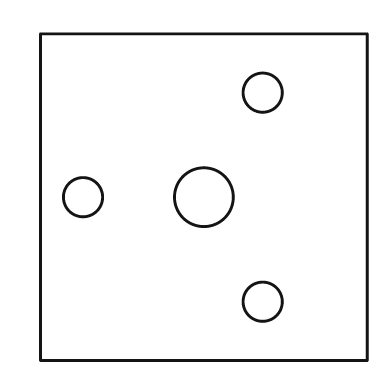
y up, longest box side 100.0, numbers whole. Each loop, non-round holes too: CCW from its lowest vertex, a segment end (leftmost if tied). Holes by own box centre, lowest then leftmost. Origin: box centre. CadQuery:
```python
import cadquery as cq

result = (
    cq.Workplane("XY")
    .moveTo(-50.0, -50.0)
    .lineTo(50.0, -50.0)
    .lineTo(50.0, 50.0)
    .lineTo(-50.0, 50.0)
    .close()
    .moveTo(18.0, -32.0)
    .circle(6.0)
    .moveTo(-37.0, 0.0)
    .circle(6.0)
    .moveTo(0.0, 0.0)
    .circle(9.0)
    .moveTo(18.0, 32.0)
    .circle(6.0)
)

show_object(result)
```